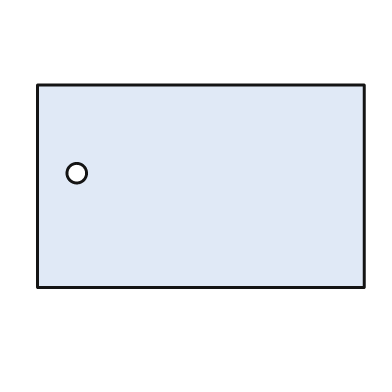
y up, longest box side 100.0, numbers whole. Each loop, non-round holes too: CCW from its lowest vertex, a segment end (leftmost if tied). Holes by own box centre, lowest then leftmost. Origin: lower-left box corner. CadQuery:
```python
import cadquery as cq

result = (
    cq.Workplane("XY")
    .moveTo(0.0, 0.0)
    .lineTo(100.0, 0.0)
    .lineTo(100.0, 62.0)
    .lineTo(0.0, 62.0)
    .close()
    .moveTo(12.0, 35.0)
    .circle(3.0)
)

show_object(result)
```